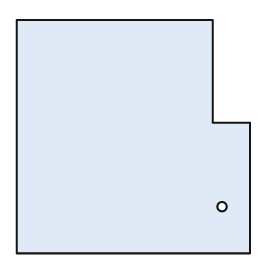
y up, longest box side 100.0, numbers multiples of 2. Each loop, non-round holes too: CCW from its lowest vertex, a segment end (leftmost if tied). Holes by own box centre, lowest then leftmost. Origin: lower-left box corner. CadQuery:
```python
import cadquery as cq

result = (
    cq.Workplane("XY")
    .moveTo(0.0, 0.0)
    .lineTo(100.0, 0.0)
    .lineTo(100.0, 56.0)
    .lineTo(84.0, 56.0)
    .lineTo(84.0, 100.0)
    .lineTo(0.0, 100.0)
    .close()
    .moveTo(88.0, 20.0)
    .circle(2.0)
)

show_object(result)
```